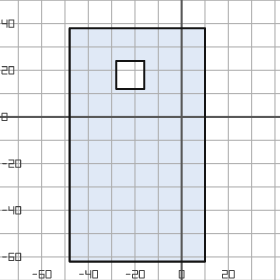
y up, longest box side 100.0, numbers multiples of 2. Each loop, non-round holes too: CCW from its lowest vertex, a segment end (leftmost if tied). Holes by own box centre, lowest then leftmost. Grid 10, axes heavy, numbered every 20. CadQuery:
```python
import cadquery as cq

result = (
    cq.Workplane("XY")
    .moveTo(-48.0, -62.0)
    .lineTo(10.0, -62.0)
    .lineTo(10.0, 38.0)
    .lineTo(-48.0, 38.0)
    .close()
    .moveTo(-28.0, 12.0)
    .lineTo(-16.0, 12.0)
    .lineTo(-16.0, 24.0)
    .lineTo(-28.0, 24.0)
    .close()
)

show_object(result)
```